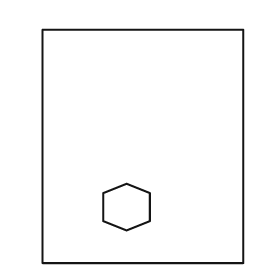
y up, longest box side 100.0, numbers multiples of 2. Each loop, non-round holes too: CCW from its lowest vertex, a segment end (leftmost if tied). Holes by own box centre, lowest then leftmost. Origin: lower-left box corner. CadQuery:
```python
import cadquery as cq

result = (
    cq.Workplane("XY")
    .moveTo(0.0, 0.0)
    .lineTo(86.0, 0.0)
    .lineTo(86.0, 100.0)
    .lineTo(0.0, 100.0)
    .close()
    .moveTo(36.0, 14.0)
    .lineTo(46.0, 18.0)
    .lineTo(46.0, 30.0)
    .lineTo(36.0, 34.0)
    .lineTo(26.0, 30.0)
    .lineTo(26.0, 18.0)
    .close()
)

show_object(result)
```